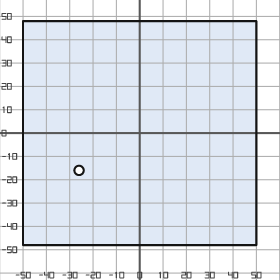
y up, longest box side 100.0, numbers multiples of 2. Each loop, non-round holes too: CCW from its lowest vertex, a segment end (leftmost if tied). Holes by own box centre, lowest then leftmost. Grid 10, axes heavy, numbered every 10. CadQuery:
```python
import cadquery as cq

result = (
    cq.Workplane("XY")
    .moveTo(-50.0, -48.0)
    .lineTo(50.0, -48.0)
    .lineTo(50.0, 48.0)
    .lineTo(-50.0, 48.0)
    .close()
    .moveTo(-26.0, -16.0)
    .circle(2.0)
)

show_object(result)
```